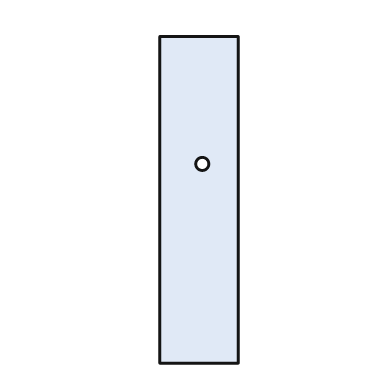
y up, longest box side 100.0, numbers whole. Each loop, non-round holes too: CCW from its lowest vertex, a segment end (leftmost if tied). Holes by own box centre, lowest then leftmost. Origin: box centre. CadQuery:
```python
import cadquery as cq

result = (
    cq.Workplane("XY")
    .moveTo(-12.0, -50.0)
    .lineTo(12.0, -50.0)
    .lineTo(12.0, 50.0)
    .lineTo(-12.0, 50.0)
    .close()
    .moveTo(1.0, 11.0)
    .circle(2.0)
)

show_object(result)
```